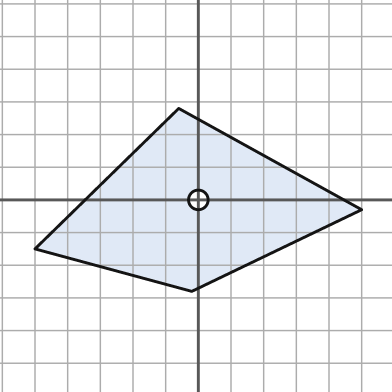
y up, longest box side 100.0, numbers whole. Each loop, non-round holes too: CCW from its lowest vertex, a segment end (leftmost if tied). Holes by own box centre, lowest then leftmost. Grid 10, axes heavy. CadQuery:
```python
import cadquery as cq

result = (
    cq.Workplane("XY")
    .moveTo(-2.0, -28.0)
    .lineTo(50.0, -3.0)
    .lineTo(-6.0, 28.0)
    .lineTo(-50.0, -15.0)
    .close()
    .moveTo(0.0, 0.0)
    .circle(3.0)
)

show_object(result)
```